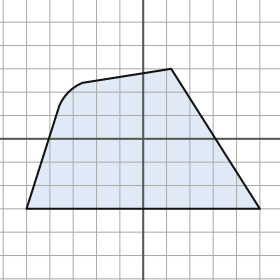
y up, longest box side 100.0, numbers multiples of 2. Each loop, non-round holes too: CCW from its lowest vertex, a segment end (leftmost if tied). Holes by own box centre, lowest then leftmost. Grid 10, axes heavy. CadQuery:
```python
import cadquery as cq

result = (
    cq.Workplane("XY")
    .moveTo(-50.0, -30.0)
    .lineTo(50.0, -30.0)
    .lineTo(12.0, 30.0)
    .lineTo(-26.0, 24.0)
    .threePointArc((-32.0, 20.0), (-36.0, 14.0))
    .close()
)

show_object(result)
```